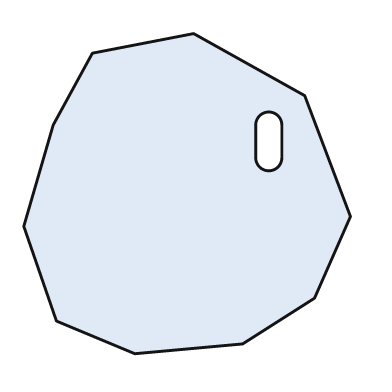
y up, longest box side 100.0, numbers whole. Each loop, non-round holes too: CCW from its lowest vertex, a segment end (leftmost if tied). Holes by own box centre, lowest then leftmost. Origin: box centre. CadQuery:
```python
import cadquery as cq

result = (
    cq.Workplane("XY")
    .moveTo(-16.0, -49.0)
    .lineTo(17.0, -46.0)
    .lineTo(39.0, -32.0)
    .lineTo(50.0, -7.0)
    .lineTo(36.0, 30.0)
    .lineTo(2.0, 49.0)
    .lineTo(-29.0, 43.0)
    .lineTo(-41.0, 21.0)
    .lineTo(-50.0, -10.0)
    .lineTo(-40.0, -39.0)
    .close()
    .moveTo(21.0, 11.0)
    .threePointArc((25.0, 7.0), (29.0, 11.0))
    .lineTo(29.0, 21.0)
    .threePointArc((25.0, 25.0), (21.0, 21.0))
    .close()
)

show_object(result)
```